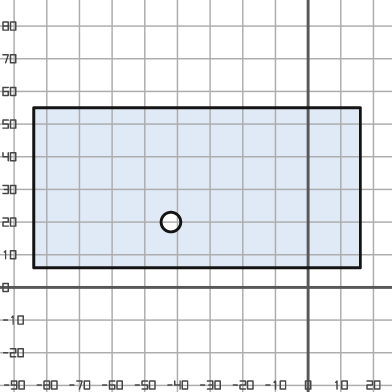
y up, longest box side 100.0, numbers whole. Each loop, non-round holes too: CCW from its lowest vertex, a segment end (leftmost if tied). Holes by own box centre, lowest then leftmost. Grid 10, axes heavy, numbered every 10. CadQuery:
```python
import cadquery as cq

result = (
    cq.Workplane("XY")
    .moveTo(-84.0, 6.0)
    .lineTo(16.0, 6.0)
    .lineTo(16.0, 55.0)
    .lineTo(-84.0, 55.0)
    .close()
    .moveTo(-42.0, 20.0)
    .circle(3.0)
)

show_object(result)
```